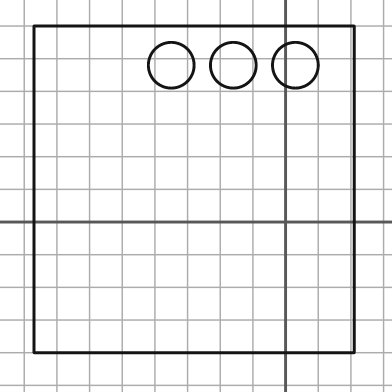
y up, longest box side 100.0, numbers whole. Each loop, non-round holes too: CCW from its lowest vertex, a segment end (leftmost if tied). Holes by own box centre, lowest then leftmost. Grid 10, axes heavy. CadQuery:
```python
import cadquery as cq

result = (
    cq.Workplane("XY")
    .moveTo(-77.0, -40.0)
    .lineTo(21.0, -40.0)
    .lineTo(21.0, 60.0)
    .lineTo(-77.0, 60.0)
    .close()
    .moveTo(-35.0, 48.0)
    .circle(7.0)
    .moveTo(-16.0, 48.0)
    .circle(7.0)
    .moveTo(3.0, 48.0)
    .circle(7.0)
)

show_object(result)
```